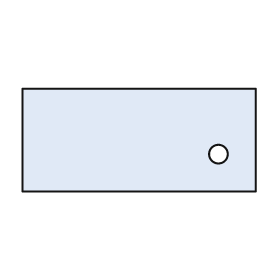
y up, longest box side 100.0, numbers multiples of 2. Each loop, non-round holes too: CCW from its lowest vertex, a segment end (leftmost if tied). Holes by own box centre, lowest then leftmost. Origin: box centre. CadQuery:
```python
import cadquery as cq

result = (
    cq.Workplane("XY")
    .moveTo(-50.0, -22.0)
    .lineTo(50.0, -22.0)
    .lineTo(50.0, 22.0)
    .lineTo(-50.0, 22.0)
    .close()
    .moveTo(34.0, -6.0)
    .circle(4.0)
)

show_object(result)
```